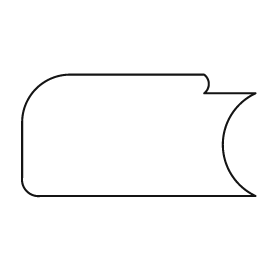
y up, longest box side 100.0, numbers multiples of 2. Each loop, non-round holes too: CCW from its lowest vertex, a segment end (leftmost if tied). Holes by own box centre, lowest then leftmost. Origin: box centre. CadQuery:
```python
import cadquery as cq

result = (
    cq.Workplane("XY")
    .moveTo(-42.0, -26.0)
    .lineTo(50.0, -26.0)
    .threePointArc((36.0, -4.0), (50.0, 18.0))
    .lineTo(28.0, 18.0)
    .threePointArc((30.0, 22.0), (28.0, 26.0))
    .lineTo(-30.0, 26.0)
    .threePointArc((-44.0, 20.0), (-50.0, 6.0))
    .lineTo(-50.0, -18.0)
    .threePointArc((-48.0, -24.0), (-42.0, -26.0))
    .close()
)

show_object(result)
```